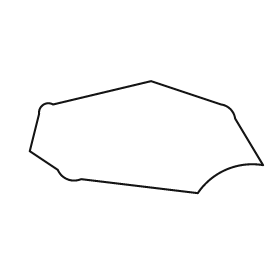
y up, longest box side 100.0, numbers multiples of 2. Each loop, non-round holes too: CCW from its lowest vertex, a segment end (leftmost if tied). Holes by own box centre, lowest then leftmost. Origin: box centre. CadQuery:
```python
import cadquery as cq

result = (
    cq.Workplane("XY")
    .moveTo(22.0, -24.0)
    .threePointArc((34.0, -14.0), (50.0, -12.0))
    .lineTo(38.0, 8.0)
    .threePointArc((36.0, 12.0), (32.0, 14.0))
    .lineTo(2.0, 24.0)
    .lineTo(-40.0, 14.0)
    .threePointArc((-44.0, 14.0), (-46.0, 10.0))
    .lineTo(-50.0, -6.0)
    .lineTo(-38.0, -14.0)
    .threePointArc((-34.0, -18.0), (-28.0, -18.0))
    .close()
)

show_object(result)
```